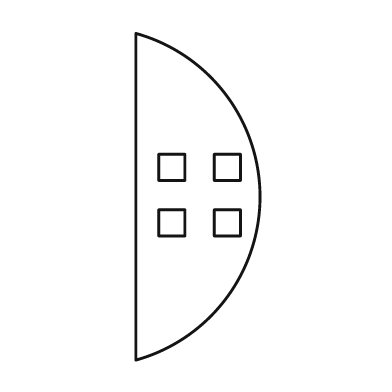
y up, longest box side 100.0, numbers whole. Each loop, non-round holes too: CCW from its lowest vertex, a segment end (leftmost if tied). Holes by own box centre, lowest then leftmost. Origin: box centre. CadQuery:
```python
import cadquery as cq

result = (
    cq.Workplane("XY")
    .moveTo(-19.0, -50.0)
    .threePointArc((19.0, 0.0), (-19.0, 50.0))
    .close()
    .moveTo(-12.0, -12.0)
    .lineTo(-4.0, -12.0)
    .lineTo(-4.0, -4.0)
    .lineTo(-12.0, -4.0)
    .close()
    .moveTo(5.0, -12.0)
    .lineTo(13.0, -12.0)
    .lineTo(13.0, -4.0)
    .lineTo(5.0, -4.0)
    .close()
    .moveTo(-12.0, 5.0)
    .lineTo(-4.0, 5.0)
    .lineTo(-4.0, 13.0)
    .lineTo(-12.0, 13.0)
    .close()
    .moveTo(5.0, 5.0)
    .lineTo(13.0, 5.0)
    .lineTo(13.0, 13.0)
    .lineTo(5.0, 13.0)
    .close()
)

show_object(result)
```